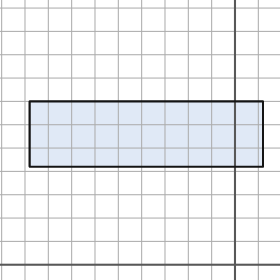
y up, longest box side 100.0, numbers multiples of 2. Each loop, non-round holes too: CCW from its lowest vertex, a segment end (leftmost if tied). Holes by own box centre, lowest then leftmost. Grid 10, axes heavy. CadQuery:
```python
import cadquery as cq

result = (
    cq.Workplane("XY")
    .moveTo(-88.0, 42.0)
    .lineTo(12.0, 42.0)
    .lineTo(12.0, 70.0)
    .lineTo(-88.0, 70.0)
    .close()
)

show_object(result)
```